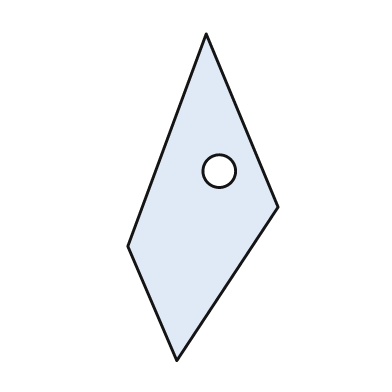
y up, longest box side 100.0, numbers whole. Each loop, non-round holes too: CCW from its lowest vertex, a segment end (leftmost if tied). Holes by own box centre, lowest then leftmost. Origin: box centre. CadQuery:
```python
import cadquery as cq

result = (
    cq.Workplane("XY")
    .moveTo(-8.0, -50.0)
    .lineTo(23.0, -3.0)
    .lineTo(1.0, 50.0)
    .lineTo(-23.0, -15.0)
    .close()
    .moveTo(5.0, 8.0)
    .circle(5.0)
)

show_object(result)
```